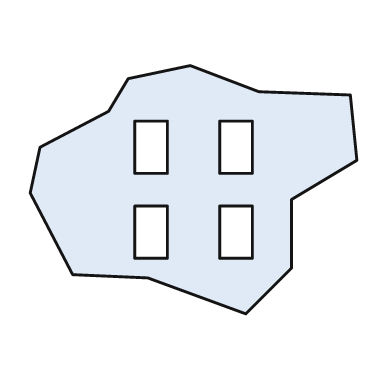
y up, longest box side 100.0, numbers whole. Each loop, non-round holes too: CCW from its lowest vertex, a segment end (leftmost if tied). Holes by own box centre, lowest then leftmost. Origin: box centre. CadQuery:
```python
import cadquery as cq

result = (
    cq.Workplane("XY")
    .moveTo(16.0, -38.0)
    .lineTo(30.0, -24.0)
    .lineTo(30.0, -3.0)
    .lineTo(50.0, 9.0)
    .lineTo(48.0, 29.0)
    .lineTo(20.0, 30.0)
    .lineTo(-1.0, 38.0)
    .lineTo(-20.0, 34.0)
    .lineTo(-26.0, 24.0)
    .lineTo(-47.0, 13.0)
    .lineTo(-50.0, -1.0)
    .lineTo(-37.0, -26.0)
    .lineTo(-14.0, -27.0)
    .close()
    .moveTo(-18.0, -21.0)
    .lineTo(-8.0, -21.0)
    .lineTo(-8.0, -5.0)
    .lineTo(-18.0, -5.0)
    .close()
    .moveTo(8.0, -21.0)
    .lineTo(18.0, -21.0)
    .lineTo(18.0, -5.0)
    .lineTo(8.0, -5.0)
    .close()
    .moveTo(-18.0, 5.0)
    .lineTo(-8.0, 5.0)
    .lineTo(-8.0, 21.0)
    .lineTo(-18.0, 21.0)
    .close()
    .moveTo(8.0, 5.0)
    .lineTo(18.0, 5.0)
    .lineTo(18.0, 21.0)
    .lineTo(8.0, 21.0)
    .close()
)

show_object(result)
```